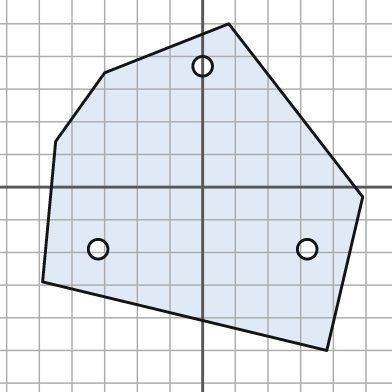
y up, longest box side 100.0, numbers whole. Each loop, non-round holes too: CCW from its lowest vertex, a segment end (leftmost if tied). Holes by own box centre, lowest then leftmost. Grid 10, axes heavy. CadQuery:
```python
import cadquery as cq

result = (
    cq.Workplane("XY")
    .moveTo(38.0, -50.0)
    .lineTo(49.0, -3.0)
    .lineTo(8.0, 50.0)
    .lineTo(-30.0, 35.0)
    .lineTo(-45.0, 14.0)
    .lineTo(-49.0, -29.0)
    .close()
    .moveTo(-32.0, -19.0)
    .circle(3.0)
    .moveTo(32.0, -19.0)
    .circle(3.0)
    .moveTo(0.0, 37.0)
    .circle(3.0)
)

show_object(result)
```